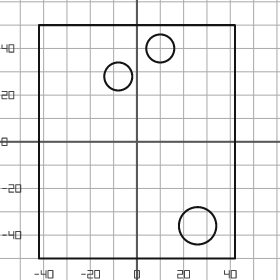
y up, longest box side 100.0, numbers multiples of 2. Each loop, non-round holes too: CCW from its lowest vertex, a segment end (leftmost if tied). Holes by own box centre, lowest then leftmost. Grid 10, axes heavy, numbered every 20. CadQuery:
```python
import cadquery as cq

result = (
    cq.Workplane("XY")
    .moveTo(-42.0, -50.0)
    .lineTo(42.0, -50.0)
    .lineTo(42.0, 50.0)
    .lineTo(-42.0, 50.0)
    .close()
    .moveTo(26.0, -36.0)
    .circle(8.0)
    .moveTo(-8.0, 28.0)
    .circle(6.0)
    .moveTo(10.0, 40.0)
    .circle(6.0)
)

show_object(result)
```